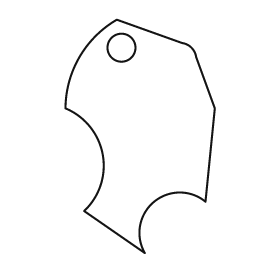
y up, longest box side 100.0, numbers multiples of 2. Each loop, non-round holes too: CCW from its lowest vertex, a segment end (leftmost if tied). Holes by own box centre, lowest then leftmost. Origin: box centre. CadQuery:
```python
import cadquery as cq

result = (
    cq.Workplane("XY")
    .moveTo(2.0, -50.0)
    .threePointArc((6.0, -28.0), (28.0, -28.0))
    .lineTo(32.0, 12.0)
    .lineTo(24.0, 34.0)
    .threePointArc((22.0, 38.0), (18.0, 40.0))
    .lineTo(-10.0, 50.0)
    .threePointArc((-26.0, 34.0), (-32.0, 12.0))
    .threePointArc((-16.0, -8.0), (-24.0, -32.0))
    .close()
    .moveTo(-8.0, 38.0)
    .circle(6.0)
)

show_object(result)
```